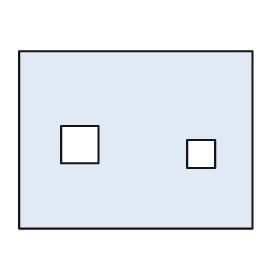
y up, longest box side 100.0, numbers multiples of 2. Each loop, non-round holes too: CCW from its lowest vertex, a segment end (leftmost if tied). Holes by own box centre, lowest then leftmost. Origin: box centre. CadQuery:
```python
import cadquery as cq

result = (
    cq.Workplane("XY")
    .moveTo(-50.0, -38.0)
    .lineTo(50.0, -38.0)
    .lineTo(50.0, 38.0)
    .lineTo(-50.0, 38.0)
    .close()
    .moveTo(22.0, -12.0)
    .lineTo(34.0, -12.0)
    .lineTo(34.0, 0.0)
    .lineTo(22.0, 0.0)
    .close()
    .moveTo(-32.0, -10.0)
    .lineTo(-16.0, -10.0)
    .lineTo(-16.0, 6.0)
    .lineTo(-32.0, 6.0)
    .close()
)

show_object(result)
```